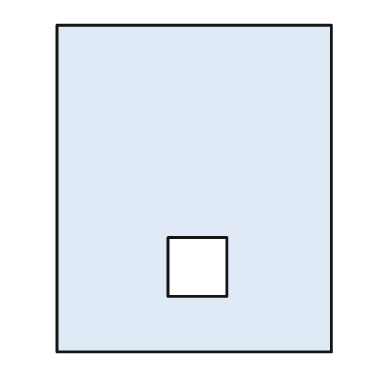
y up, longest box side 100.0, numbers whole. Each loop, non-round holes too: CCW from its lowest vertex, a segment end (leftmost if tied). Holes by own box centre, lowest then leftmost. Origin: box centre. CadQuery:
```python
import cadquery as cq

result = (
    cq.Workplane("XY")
    .moveTo(-42.0, -50.0)
    .lineTo(42.0, -50.0)
    .lineTo(42.0, 50.0)
    .lineTo(-42.0, 50.0)
    .close()
    .moveTo(-8.0, -33.0)
    .lineTo(10.0, -33.0)
    .lineTo(10.0, -15.0)
    .lineTo(-8.0, -15.0)
    .close()
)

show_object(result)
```